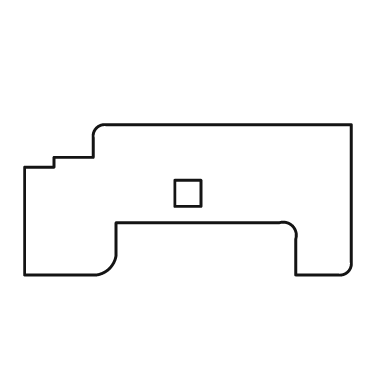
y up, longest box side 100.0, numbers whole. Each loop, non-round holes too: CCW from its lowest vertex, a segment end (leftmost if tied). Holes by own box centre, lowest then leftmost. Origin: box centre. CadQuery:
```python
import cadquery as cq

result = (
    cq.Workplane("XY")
    .moveTo(-50.0, -23.0)
    .lineTo(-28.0, -23.0)
    .threePointArc((-24.0, -21.0), (-22.0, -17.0))
    .lineTo(-22.0, -7.0)
    .lineTo(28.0, -7.0)
    .threePointArc((32.0, -8.0), (33.0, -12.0))
    .lineTo(33.0, -23.0)
    .lineTo(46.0, -23.0)
    .threePointArc((49.0, -22.0), (50.0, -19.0))
    .lineTo(50.0, 23.0)
    .lineTo(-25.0, 23.0)
    .threePointArc((-28.0, 22.0), (-29.0, 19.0))
    .lineTo(-29.0, 13.0)
    .lineTo(-41.0, 13.0)
    .lineTo(-41.0, 10.0)
    .lineTo(-50.0, 10.0)
    .close()
    .moveTo(-4.0, -2.0)
    .lineTo(4.0, -2.0)
    .lineTo(4.0, 6.0)
    .lineTo(-4.0, 6.0)
    .close()
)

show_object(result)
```